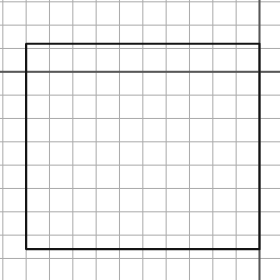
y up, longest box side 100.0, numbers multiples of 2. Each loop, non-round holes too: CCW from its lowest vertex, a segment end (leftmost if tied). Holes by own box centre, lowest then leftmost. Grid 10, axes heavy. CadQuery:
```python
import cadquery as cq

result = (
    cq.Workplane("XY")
    .moveTo(-100.0, -76.0)
    .lineTo(0.0, -76.0)
    .lineTo(0.0, 12.0)
    .lineTo(-100.0, 12.0)
    .close()
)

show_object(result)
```